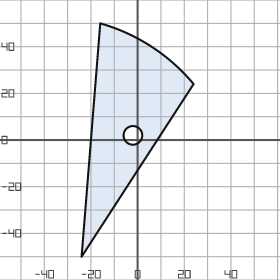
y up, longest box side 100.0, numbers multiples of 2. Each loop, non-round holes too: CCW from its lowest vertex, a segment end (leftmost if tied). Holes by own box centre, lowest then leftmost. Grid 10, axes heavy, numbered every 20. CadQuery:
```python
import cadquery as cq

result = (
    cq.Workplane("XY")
    .moveTo(-24.0, -50.0)
    .lineTo(24.0, 24.0)
    .threePointArc((6.0, 40.0), (-16.0, 50.0))
    .close()
    .moveTo(-2.0, 2.0)
    .circle(4.0)
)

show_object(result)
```